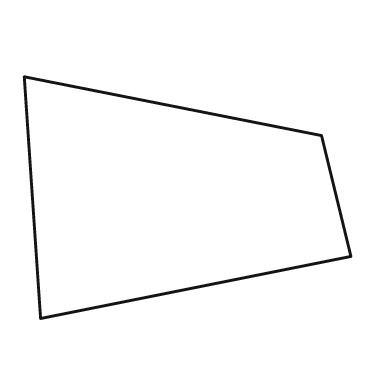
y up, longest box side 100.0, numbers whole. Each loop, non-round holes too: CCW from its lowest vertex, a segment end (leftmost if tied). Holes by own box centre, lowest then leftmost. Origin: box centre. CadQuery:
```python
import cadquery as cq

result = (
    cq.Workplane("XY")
    .moveTo(-45.0, -37.0)
    .lineTo(50.0, -18.0)
    .lineTo(41.0, 19.0)
    .lineTo(-50.0, 37.0)
    .close()
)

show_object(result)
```